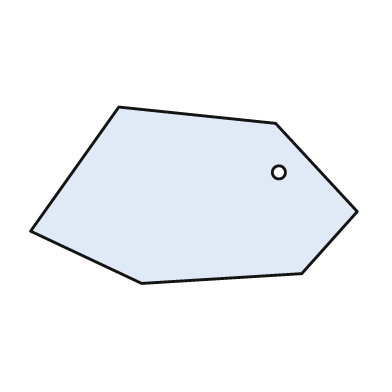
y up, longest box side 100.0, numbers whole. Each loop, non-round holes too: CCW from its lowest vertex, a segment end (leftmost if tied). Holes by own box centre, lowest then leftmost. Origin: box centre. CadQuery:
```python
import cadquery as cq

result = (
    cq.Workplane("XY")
    .moveTo(-16.0, -27.0)
    .lineTo(33.0, -24.0)
    .lineTo(50.0, -5.0)
    .lineTo(25.0, 22.0)
    .lineTo(-23.0, 27.0)
    .lineTo(-50.0, -11.0)
    .close()
    .moveTo(26.0, 7.0)
    .circle(2.0)
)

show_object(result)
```